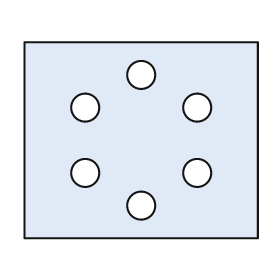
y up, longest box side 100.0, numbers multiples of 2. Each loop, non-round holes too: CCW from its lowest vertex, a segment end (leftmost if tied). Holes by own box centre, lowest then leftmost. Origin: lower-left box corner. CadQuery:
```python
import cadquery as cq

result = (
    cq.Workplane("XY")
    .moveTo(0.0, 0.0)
    .lineTo(100.0, 0.0)
    .lineTo(100.0, 84.0)
    .lineTo(0.0, 84.0)
    .close()
    .moveTo(50.0, 14.0)
    .circle(6.0)
    .moveTo(26.0, 28.0)
    .circle(6.0)
    .moveTo(74.0, 28.0)
    .circle(6.0)
    .moveTo(26.0, 56.0)
    .circle(6.0)
    .moveTo(74.0, 56.0)
    .circle(6.0)
    .moveTo(50.0, 70.0)
    .circle(6.0)
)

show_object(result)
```